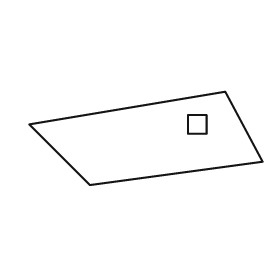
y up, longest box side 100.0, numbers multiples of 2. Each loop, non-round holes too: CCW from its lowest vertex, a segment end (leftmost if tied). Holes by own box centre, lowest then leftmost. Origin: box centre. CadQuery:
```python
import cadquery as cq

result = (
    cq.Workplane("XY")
    .moveTo(-24.0, -20.0)
    .lineTo(50.0, -10.0)
    .lineTo(34.0, 20.0)
    .lineTo(-50.0, 6.0)
    .close()
    .moveTo(18.0, 2.0)
    .lineTo(26.0, 2.0)
    .lineTo(26.0, 10.0)
    .lineTo(18.0, 10.0)
    .close()
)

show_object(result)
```